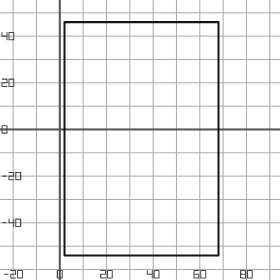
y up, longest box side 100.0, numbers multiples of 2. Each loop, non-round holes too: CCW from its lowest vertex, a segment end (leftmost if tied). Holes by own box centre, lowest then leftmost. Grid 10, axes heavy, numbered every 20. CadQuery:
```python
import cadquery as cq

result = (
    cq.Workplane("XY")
    .moveTo(2.0, -54.0)
    .lineTo(68.0, -54.0)
    .lineTo(68.0, 46.0)
    .lineTo(2.0, 46.0)
    .close()
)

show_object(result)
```